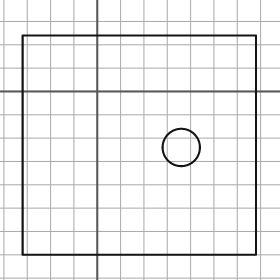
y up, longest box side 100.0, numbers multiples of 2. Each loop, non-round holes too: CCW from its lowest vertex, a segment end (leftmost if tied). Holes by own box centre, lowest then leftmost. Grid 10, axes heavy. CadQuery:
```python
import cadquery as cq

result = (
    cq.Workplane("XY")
    .moveTo(-32.0, -70.0)
    .lineTo(68.0, -70.0)
    .lineTo(68.0, 24.0)
    .lineTo(-32.0, 24.0)
    .close()
    .moveTo(36.0, -24.0)
    .circle(8.0)
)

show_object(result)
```